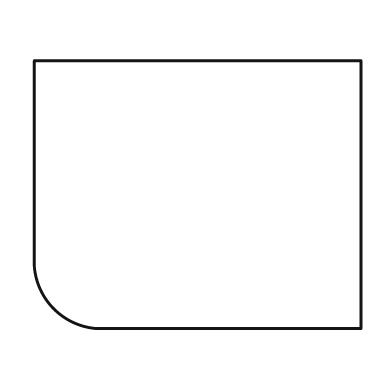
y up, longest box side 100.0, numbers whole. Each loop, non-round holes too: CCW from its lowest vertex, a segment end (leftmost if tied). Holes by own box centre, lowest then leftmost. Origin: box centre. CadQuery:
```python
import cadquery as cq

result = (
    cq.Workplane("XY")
    .moveTo(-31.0, -41.0)
    .lineTo(50.0, -41.0)
    .lineTo(50.0, 41.0)
    .lineTo(-50.0, 41.0)
    .lineTo(-50.0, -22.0)
    .threePointArc((-44.0, -35.0), (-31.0, -41.0))
    .close()
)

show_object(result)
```